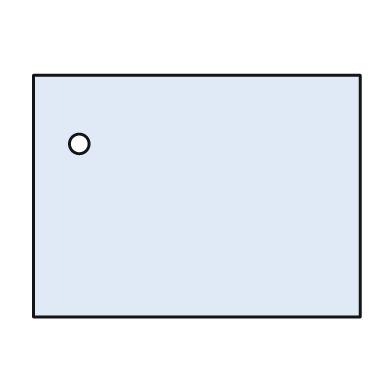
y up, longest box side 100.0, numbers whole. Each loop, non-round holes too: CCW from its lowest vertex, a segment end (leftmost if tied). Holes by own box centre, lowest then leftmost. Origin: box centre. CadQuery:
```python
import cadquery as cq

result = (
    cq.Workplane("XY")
    .moveTo(-50.0, -37.0)
    .lineTo(50.0, -37.0)
    .lineTo(50.0, 37.0)
    .lineTo(-50.0, 37.0)
    .close()
    .moveTo(-36.0, 16.0)
    .circle(3.0)
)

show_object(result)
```